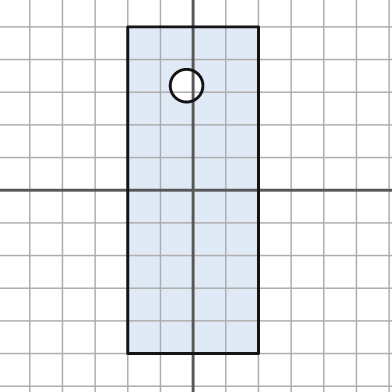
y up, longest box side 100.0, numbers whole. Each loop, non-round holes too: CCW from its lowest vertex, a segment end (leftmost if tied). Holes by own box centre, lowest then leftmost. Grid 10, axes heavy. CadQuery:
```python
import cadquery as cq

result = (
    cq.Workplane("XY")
    .moveTo(-20.0, -50.0)
    .lineTo(20.0, -50.0)
    .lineTo(20.0, 50.0)
    .lineTo(-20.0, 50.0)
    .close()
    .moveTo(-2.0, 32.0)
    .circle(5.0)
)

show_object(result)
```